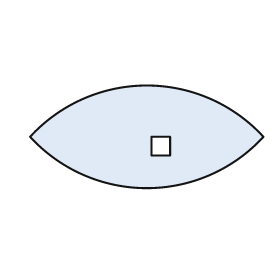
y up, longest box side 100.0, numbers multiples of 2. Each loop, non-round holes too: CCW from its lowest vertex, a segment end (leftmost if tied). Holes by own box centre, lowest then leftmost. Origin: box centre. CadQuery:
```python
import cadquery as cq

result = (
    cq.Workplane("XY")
    .moveTo(-50.0, 0.0)
    .threePointArc((0.0, -22.0), (50.0, 0.0))
    .threePointArc((0.0, 22.0), (-50.0, 0.0))
    .close()
    .moveTo(2.0, -8.0)
    .lineTo(10.0, -8.0)
    .lineTo(10.0, 0.0)
    .lineTo(2.0, 0.0)
    .close()
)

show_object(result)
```